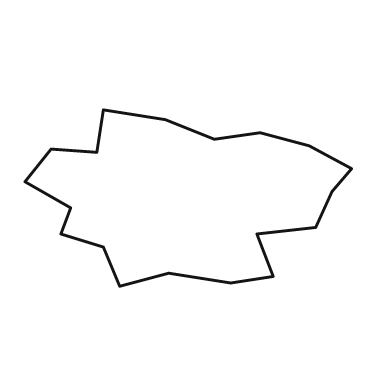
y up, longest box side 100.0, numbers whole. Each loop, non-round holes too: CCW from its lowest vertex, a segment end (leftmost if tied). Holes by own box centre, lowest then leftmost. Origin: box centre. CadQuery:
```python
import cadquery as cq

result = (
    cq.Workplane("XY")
    .moveTo(-21.0, -27.0)
    .lineTo(-6.0, -23.0)
    .lineTo(13.0, -26.0)
    .lineTo(26.0, -24.0)
    .lineTo(21.0, -11.0)
    .lineTo(39.0, -9.0)
    .lineTo(44.0, 2.0)
    .lineTo(50.0, 9.0)
    .lineTo(37.0, 16.0)
    .lineTo(22.0, 20.0)
    .lineTo(8.0, 18.0)
    .lineTo(-7.0, 24.0)
    .lineTo(-26.0, 27.0)
    .lineTo(-28.0, 14.0)
    .lineTo(-42.0, 15.0)
    .lineTo(-50.0, 5.0)
    .lineTo(-36.0, -3.0)
    .lineTo(-39.0, -11.0)
    .lineTo(-26.0, -15.0)
    .close()
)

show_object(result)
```